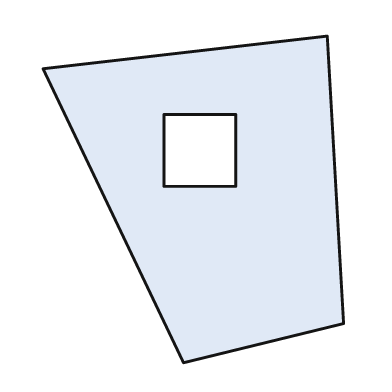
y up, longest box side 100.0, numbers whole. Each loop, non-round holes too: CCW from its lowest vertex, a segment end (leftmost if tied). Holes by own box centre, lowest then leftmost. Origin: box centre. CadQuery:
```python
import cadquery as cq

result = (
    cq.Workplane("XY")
    .moveTo(-3.0, -50.0)
    .lineTo(46.0, -38.0)
    .lineTo(41.0, 50.0)
    .lineTo(-46.0, 40.0)
    .close()
    .moveTo(-9.0, 4.0)
    .lineTo(13.0, 4.0)
    .lineTo(13.0, 26.0)
    .lineTo(-9.0, 26.0)
    .close()
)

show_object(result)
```